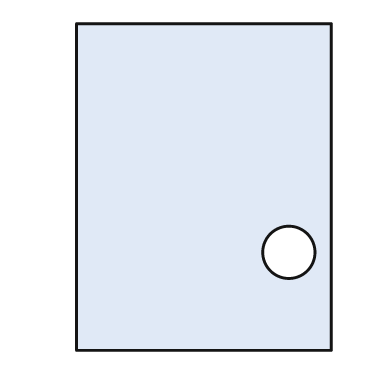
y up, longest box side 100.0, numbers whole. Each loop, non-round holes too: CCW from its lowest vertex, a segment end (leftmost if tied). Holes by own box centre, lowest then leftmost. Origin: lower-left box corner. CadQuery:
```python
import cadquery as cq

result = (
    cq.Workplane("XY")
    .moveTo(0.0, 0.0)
    .lineTo(78.0, 0.0)
    .lineTo(78.0, 100.0)
    .lineTo(0.0, 100.0)
    .close()
    .moveTo(65.0, 30.0)
    .circle(8.0)
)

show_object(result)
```